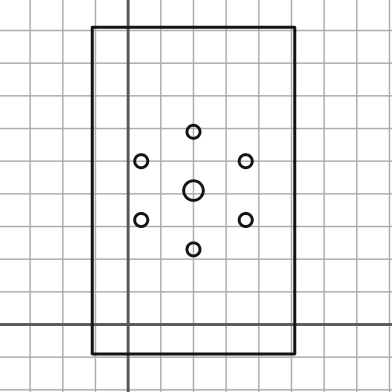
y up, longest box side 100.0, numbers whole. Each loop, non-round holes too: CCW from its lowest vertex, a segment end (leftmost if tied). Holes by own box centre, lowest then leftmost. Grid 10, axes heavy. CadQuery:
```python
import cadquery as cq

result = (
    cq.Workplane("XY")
    .moveTo(-11.0, -9.0)
    .lineTo(51.0, -9.0)
    .lineTo(51.0, 91.0)
    .lineTo(-11.0, 91.0)
    .close()
    .moveTo(20.0, 23.0)
    .circle(2.0)
    .moveTo(4.0, 32.0)
    .circle(2.0)
    .moveTo(36.0, 32.0)
    .circle(2.0)
    .moveTo(20.0, 41.0)
    .circle(3.0)
    .moveTo(4.0, 50.0)
    .circle(2.0)
    .moveTo(36.0, 50.0)
    .circle(2.0)
    .moveTo(20.0, 59.0)
    .circle(2.0)
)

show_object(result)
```